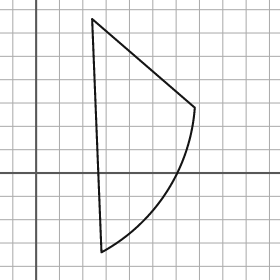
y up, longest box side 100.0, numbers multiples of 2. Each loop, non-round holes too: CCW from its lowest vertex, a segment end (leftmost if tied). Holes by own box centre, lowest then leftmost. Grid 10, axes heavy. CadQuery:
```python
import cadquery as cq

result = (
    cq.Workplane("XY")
    .moveTo(28.0, -34.0)
    .threePointArc((56.0, -8.0), (68.0, 28.0))
    .lineTo(24.0, 66.0)
    .close()
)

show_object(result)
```